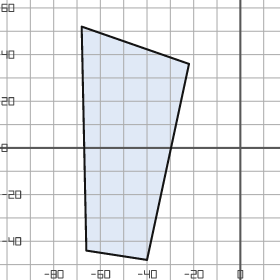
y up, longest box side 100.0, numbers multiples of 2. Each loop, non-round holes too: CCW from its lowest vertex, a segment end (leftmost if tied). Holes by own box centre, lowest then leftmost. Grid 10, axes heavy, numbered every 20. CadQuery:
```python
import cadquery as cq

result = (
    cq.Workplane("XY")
    .moveTo(-40.0, -48.0)
    .lineTo(-22.0, 36.0)
    .lineTo(-68.0, 52.0)
    .lineTo(-66.0, -44.0)
    .close()
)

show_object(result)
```